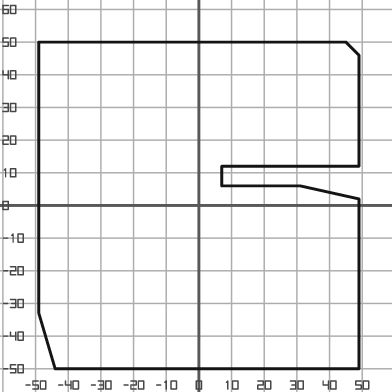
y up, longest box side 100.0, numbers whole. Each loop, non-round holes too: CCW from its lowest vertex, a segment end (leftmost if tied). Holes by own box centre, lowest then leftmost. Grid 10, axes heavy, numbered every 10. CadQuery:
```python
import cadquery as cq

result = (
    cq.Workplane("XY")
    .moveTo(-44.0, -50.0)
    .lineTo(49.0, -50.0)
    .lineTo(49.0, 2.0)
    .lineTo(31.0, 6.0)
    .lineTo(7.0, 6.0)
    .lineTo(7.0, 12.0)
    .lineTo(49.0, 12.0)
    .lineTo(49.0, 46.0)
    .lineTo(45.0, 50.0)
    .lineTo(-49.0, 50.0)
    .lineTo(-49.0, -33.0)
    .close()
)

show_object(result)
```